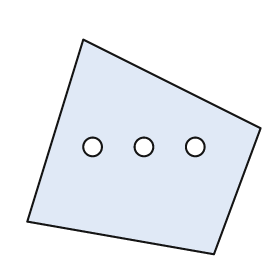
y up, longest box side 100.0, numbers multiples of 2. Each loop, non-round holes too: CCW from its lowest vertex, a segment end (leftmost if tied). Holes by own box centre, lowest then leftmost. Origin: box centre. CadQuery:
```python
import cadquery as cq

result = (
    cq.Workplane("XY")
    .moveTo(30.0, -46.0)
    .lineTo(50.0, 8.0)
    .lineTo(-26.0, 46.0)
    .lineTo(-50.0, -32.0)
    .close()
    .moveTo(-22.0, 0.0)
    .circle(4.0)
    .moveTo(0.0, 0.0)
    .circle(4.0)
    .moveTo(22.0, 0.0)
    .circle(4.0)
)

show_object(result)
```